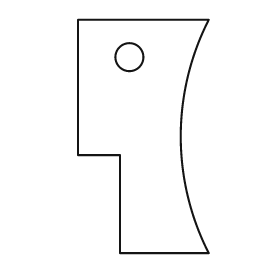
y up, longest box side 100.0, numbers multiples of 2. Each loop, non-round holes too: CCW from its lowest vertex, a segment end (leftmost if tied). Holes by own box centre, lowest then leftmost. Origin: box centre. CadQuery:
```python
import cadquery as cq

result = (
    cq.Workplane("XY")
    .moveTo(-10.0, -50.0)
    .lineTo(28.0, -50.0)
    .threePointArc((16.0, 0.0), (28.0, 50.0))
    .lineTo(-28.0, 50.0)
    .lineTo(-28.0, -8.0)
    .lineTo(-10.0, -8.0)
    .close()
    .moveTo(-6.0, 34.0)
    .circle(6.0)
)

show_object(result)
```